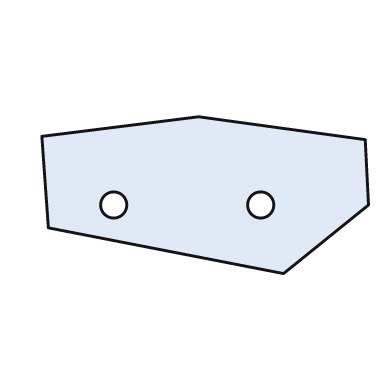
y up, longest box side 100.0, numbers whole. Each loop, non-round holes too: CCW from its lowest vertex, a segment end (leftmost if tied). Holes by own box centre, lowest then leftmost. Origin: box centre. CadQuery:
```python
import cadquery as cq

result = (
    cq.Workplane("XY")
    .moveTo(24.0, -24.0)
    .lineTo(50.0, -3.0)
    .lineTo(49.0, 17.0)
    .lineTo(-2.0, 24.0)
    .lineTo(-50.0, 18.0)
    .lineTo(-48.0, -10.0)
    .close()
    .moveTo(-28.0, -3.0)
    .circle(4.0)
    .moveTo(17.0, -3.0)
    .circle(4.0)
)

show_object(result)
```